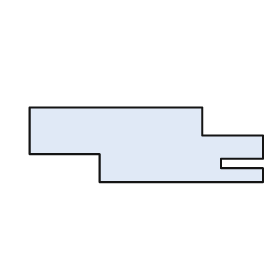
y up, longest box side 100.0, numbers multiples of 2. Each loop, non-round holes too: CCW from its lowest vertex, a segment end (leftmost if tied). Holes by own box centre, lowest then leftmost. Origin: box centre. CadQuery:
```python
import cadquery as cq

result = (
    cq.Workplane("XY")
    .moveTo(-20.0, -16.0)
    .lineTo(50.0, -16.0)
    .lineTo(50.0, -10.0)
    .lineTo(32.0, -10.0)
    .lineTo(32.0, -6.0)
    .lineTo(50.0, -6.0)
    .lineTo(50.0, 4.0)
    .lineTo(24.0, 4.0)
    .lineTo(24.0, 16.0)
    .lineTo(-50.0, 16.0)
    .lineTo(-50.0, -4.0)
    .lineTo(-20.0, -4.0)
    .close()
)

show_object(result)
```